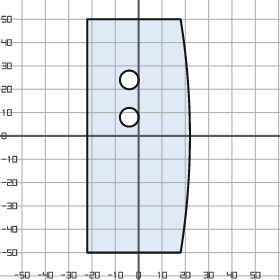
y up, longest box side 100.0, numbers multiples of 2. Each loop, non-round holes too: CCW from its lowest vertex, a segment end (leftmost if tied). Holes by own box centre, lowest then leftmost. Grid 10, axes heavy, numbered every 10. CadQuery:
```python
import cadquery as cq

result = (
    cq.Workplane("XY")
    .moveTo(-22.0, -50.0)
    .lineTo(18.0, -50.0)
    .threePointArc((22.0, 0.0), (18.0, 50.0))
    .lineTo(-22.0, 50.0)
    .close()
    .moveTo(-4.0, 8.0)
    .circle(4.0)
    .moveTo(-4.0, 24.0)
    .circle(4.0)
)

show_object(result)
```